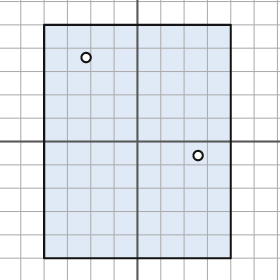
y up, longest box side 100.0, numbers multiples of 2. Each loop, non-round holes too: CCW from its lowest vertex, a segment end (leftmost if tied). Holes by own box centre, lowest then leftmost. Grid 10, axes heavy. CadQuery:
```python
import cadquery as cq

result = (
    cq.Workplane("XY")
    .moveTo(-40.0, -50.0)
    .lineTo(40.0, -50.0)
    .lineTo(40.0, 50.0)
    .lineTo(-40.0, 50.0)
    .close()
    .moveTo(26.0, -6.0)
    .circle(2.0)
    .moveTo(-22.0, 36.0)
    .circle(2.0)
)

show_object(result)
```